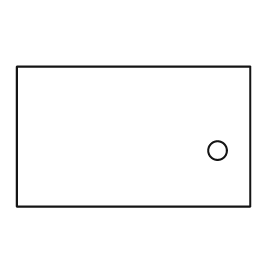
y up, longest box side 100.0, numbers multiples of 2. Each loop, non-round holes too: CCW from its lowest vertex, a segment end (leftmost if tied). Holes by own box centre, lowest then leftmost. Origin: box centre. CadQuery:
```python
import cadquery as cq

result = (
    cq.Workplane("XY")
    .moveTo(-50.0, -30.0)
    .lineTo(50.0, -30.0)
    .lineTo(50.0, 30.0)
    .lineTo(-50.0, 30.0)
    .close()
    .moveTo(36.0, -6.0)
    .circle(4.0)
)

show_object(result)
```